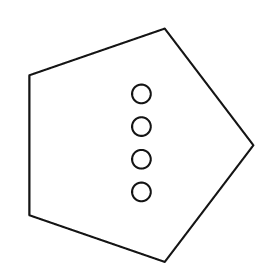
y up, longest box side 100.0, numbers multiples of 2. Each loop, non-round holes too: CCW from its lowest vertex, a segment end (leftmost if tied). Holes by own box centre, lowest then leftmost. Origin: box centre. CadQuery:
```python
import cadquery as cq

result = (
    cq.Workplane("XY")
    .moveTo(10.0, -50.0)
    .lineTo(48.0, 0.0)
    .lineTo(10.0, 50.0)
    .lineTo(-48.0, 30.0)
    .lineTo(-48.0, -30.0)
    .close()
    .moveTo(0.0, -20.0)
    .circle(4.0)
    .moveTo(0.0, -6.0)
    .circle(4.0)
    .moveTo(0.0, 8.0)
    .circle(4.0)
    .moveTo(0.0, 22.0)
    .circle(4.0)
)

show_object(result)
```